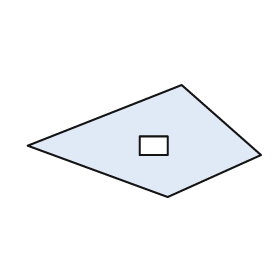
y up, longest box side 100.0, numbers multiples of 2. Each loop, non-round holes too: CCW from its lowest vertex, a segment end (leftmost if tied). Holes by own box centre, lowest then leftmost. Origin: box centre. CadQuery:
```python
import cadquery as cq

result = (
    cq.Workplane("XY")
    .moveTo(10.0, -24.0)
    .lineTo(50.0, -6.0)
    .lineTo(16.0, 24.0)
    .lineTo(-50.0, -2.0)
    .close()
    .moveTo(-2.0, -6.0)
    .lineTo(10.0, -6.0)
    .lineTo(10.0, 2.0)
    .lineTo(-2.0, 2.0)
    .close()
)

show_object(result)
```